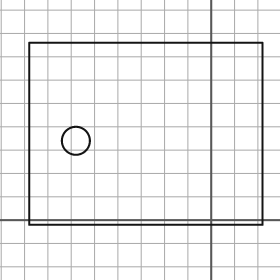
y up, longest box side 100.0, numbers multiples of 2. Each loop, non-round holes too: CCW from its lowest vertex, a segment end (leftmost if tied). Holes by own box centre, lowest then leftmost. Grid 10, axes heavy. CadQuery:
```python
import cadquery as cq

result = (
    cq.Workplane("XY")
    .moveTo(-78.0, -2.0)
    .lineTo(22.0, -2.0)
    .lineTo(22.0, 76.0)
    .lineTo(-78.0, 76.0)
    .close()
    .moveTo(-58.0, 34.0)
    .circle(6.0)
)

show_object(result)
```